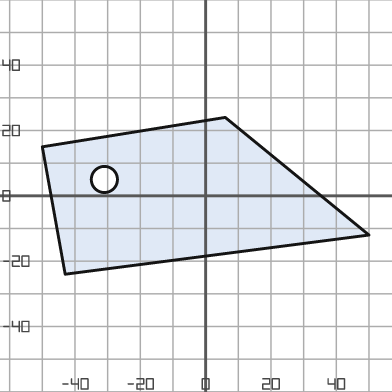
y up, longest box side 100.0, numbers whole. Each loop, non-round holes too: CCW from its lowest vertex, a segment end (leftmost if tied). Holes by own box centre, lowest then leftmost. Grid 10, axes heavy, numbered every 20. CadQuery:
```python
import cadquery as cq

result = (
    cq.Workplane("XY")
    .moveTo(-43.0, -24.0)
    .lineTo(50.0, -12.0)
    .lineTo(6.0, 24.0)
    .lineTo(-50.0, 15.0)
    .close()
    .moveTo(-31.0, 5.0)
    .circle(4.0)
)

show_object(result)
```